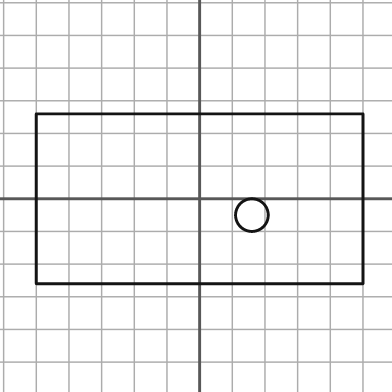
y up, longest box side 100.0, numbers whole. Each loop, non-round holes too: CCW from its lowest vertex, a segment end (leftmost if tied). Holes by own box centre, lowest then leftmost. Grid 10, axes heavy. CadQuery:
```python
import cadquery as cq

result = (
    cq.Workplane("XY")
    .moveTo(-50.0, -26.0)
    .lineTo(50.0, -26.0)
    .lineTo(50.0, 26.0)
    .lineTo(-50.0, 26.0)
    .close()
    .moveTo(16.0, -5.0)
    .circle(5.0)
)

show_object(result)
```